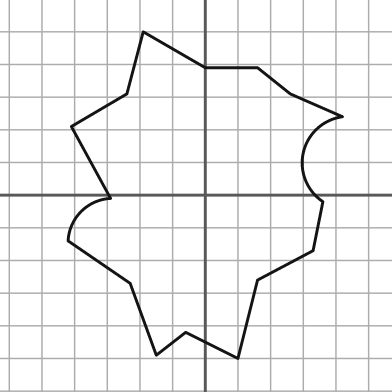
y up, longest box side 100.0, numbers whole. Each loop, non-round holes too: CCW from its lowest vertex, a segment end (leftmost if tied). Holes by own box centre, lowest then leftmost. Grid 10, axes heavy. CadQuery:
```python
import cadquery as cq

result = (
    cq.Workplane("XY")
    .moveTo(10.0, -50.0)
    .lineTo(16.0, -26.0)
    .lineTo(33.0, -17.0)
    .lineTo(36.0, -2.0)
    .threePointArc((30.0, 13.0), (42.0, 24.0))
    .lineTo(26.0, 31.0)
    .lineTo(16.0, 39.0)
    .lineTo(0.0, 39.0)
    .lineTo(-19.0, 50.0)
    .lineTo(-24.0, 31.0)
    .lineTo(-41.0, 21.0)
    .lineTo(-29.0, -1.0)
    .threePointArc((-38.0, -5.0), (-42.0, -14.0))
    .lineTo(-23.0, -27.0)
    .lineTo(-15.0, -49.0)
    .lineTo(-6.0, -42.0)
    .close()
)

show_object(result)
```